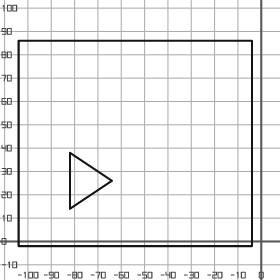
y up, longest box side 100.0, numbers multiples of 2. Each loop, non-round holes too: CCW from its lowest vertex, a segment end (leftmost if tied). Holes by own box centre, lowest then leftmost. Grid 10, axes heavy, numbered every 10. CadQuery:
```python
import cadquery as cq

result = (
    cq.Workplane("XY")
    .moveTo(-104.0, -2.0)
    .lineTo(-4.0, -2.0)
    .lineTo(-4.0, 86.0)
    .lineTo(-104.0, 86.0)
    .close()
    .moveTo(-82.0, 14.0)
    .lineTo(-64.0, 26.0)
    .lineTo(-82.0, 38.0)
    .close()
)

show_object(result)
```